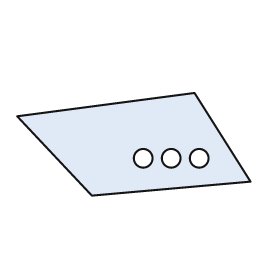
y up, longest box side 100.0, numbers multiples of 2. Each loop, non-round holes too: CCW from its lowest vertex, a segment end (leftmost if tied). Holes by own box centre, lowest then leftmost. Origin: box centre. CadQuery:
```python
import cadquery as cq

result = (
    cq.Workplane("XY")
    .moveTo(-18.0, -22.0)
    .lineTo(50.0, -16.0)
    .lineTo(26.0, 22.0)
    .lineTo(-50.0, 12.0)
    .close()
    .moveTo(4.0, -6.0)
    .circle(4.0)
    .moveTo(16.0, -6.0)
    .circle(4.0)
    .moveTo(28.0, -6.0)
    .circle(4.0)
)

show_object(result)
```